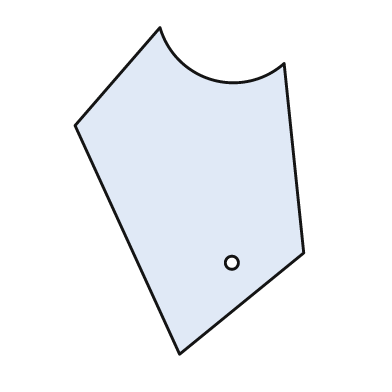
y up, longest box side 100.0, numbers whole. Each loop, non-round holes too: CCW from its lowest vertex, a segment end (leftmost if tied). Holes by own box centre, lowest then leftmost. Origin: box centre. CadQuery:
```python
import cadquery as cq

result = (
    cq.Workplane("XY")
    .moveTo(-3.0, -50.0)
    .lineTo(35.0, -19.0)
    .lineTo(29.0, 39.0)
    .threePointArc((7.0, 34.0), (-9.0, 50.0))
    .lineTo(-35.0, 20.0)
    .close()
    .moveTo(13.0, -22.0)
    .circle(2.0)
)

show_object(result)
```